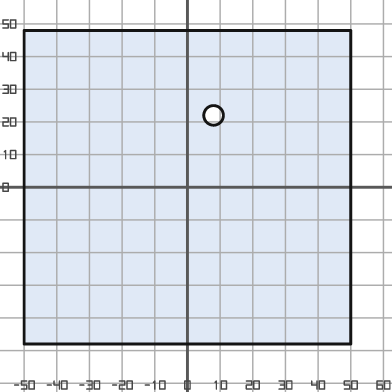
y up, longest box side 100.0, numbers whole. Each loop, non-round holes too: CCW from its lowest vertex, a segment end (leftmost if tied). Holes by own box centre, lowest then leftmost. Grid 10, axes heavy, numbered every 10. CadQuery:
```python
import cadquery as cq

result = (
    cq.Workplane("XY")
    .moveTo(-50.0, -48.0)
    .lineTo(50.0, -48.0)
    .lineTo(50.0, 48.0)
    .lineTo(-50.0, 48.0)
    .close()
    .moveTo(8.0, 22.0)
    .circle(3.0)
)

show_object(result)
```